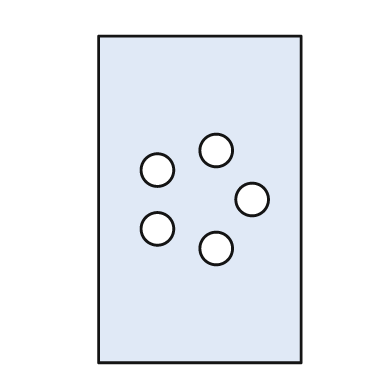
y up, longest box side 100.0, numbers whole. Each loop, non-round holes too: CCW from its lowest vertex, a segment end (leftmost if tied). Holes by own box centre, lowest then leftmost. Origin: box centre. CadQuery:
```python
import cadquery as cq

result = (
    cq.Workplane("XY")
    .moveTo(-31.0, -50.0)
    .lineTo(31.0, -50.0)
    .lineTo(31.0, 50.0)
    .lineTo(-31.0, 50.0)
    .close()
    .moveTo(5.0, -15.0)
    .circle(5.0)
    .moveTo(-13.0, -9.0)
    .circle(5.0)
    .moveTo(16.0, 0.0)
    .circle(5.0)
    .moveTo(-13.0, 9.0)
    .circle(5.0)
    .moveTo(5.0, 15.0)
    .circle(5.0)
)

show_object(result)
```